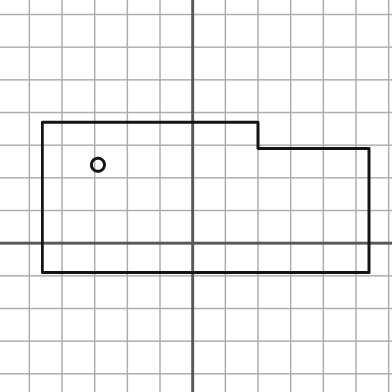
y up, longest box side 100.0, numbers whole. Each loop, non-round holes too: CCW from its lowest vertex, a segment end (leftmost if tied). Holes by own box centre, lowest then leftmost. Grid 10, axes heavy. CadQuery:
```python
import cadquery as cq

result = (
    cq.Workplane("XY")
    .moveTo(-46.0, -9.0)
    .lineTo(54.0, -9.0)
    .lineTo(54.0, 29.0)
    .lineTo(20.0, 29.0)
    .lineTo(20.0, 37.0)
    .lineTo(-46.0, 37.0)
    .close()
    .moveTo(-29.0, 24.0)
    .circle(2.0)
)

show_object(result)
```